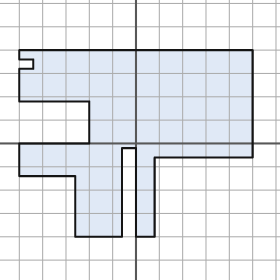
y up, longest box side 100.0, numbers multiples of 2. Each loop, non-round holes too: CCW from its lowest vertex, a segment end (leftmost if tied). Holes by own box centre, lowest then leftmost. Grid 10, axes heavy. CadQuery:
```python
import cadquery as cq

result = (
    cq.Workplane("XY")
    .moveTo(-26.0, -40.0)
    .lineTo(-6.0, -40.0)
    .lineTo(-6.0, -2.0)
    .lineTo(0.0, -2.0)
    .lineTo(0.0, -40.0)
    .lineTo(8.0, -40.0)
    .lineTo(8.0, -6.0)
    .lineTo(50.0, -6.0)
    .lineTo(50.0, 40.0)
    .lineTo(-50.0, 40.0)
    .lineTo(-50.0, 36.0)
    .lineTo(-44.0, 36.0)
    .lineTo(-44.0, 32.0)
    .lineTo(-50.0, 32.0)
    .lineTo(-50.0, 18.0)
    .lineTo(-20.0, 18.0)
    .lineTo(-20.0, 0.0)
    .lineTo(-50.0, 0.0)
    .lineTo(-50.0, -14.0)
    .lineTo(-26.0, -14.0)
    .close()
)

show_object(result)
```